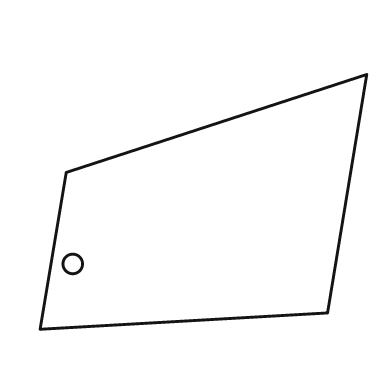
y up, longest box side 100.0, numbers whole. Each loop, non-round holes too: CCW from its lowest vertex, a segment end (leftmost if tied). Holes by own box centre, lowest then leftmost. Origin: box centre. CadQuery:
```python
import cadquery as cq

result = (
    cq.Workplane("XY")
    .moveTo(-50.0, -39.0)
    .lineTo(38.0, -34.0)
    .lineTo(50.0, 39.0)
    .lineTo(-42.0, 9.0)
    .close()
    .moveTo(-40.0, -19.0)
    .circle(3.0)
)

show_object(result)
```